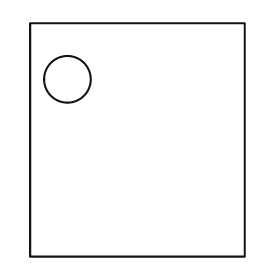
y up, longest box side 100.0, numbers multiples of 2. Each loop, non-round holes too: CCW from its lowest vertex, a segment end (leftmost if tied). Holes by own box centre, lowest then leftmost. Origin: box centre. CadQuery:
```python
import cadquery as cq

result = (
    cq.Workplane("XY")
    .moveTo(-46.0, -50.0)
    .lineTo(46.0, -50.0)
    .lineTo(46.0, 50.0)
    .lineTo(-46.0, 50.0)
    .close()
    .moveTo(-30.0, 26.0)
    .circle(10.0)
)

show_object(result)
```